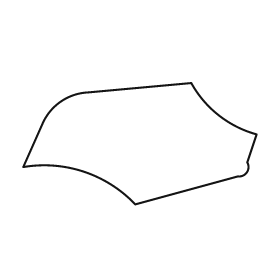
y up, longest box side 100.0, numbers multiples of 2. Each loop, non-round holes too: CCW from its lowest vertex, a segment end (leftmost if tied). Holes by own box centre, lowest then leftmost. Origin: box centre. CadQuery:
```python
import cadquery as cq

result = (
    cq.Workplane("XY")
    .moveTo(-2.0, -26.0)
    .lineTo(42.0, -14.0)
    .threePointArc((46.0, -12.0), (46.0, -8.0))
    .lineTo(50.0, 4.0)
    .threePointArc((34.0, 12.0), (22.0, 26.0))
    .lineTo(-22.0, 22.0)
    .threePointArc((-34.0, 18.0), (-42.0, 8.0))
    .lineTo(-50.0, -10.0)
    .threePointArc((-24.0, -12.0), (-2.0, -26.0))
    .close()
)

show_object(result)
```